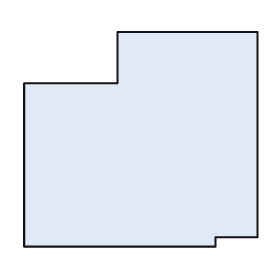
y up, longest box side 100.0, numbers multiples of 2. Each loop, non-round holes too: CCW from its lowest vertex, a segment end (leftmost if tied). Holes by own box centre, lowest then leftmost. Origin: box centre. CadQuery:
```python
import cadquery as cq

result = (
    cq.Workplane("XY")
    .moveTo(-50.0, -46.0)
    .lineTo(32.0, -46.0)
    .lineTo(32.0, -42.0)
    .lineTo(50.0, -42.0)
    .lineTo(50.0, 46.0)
    .lineTo(-10.0, 46.0)
    .lineTo(-10.0, 24.0)
    .lineTo(-50.0, 24.0)
    .close()
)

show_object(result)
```